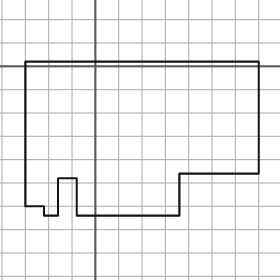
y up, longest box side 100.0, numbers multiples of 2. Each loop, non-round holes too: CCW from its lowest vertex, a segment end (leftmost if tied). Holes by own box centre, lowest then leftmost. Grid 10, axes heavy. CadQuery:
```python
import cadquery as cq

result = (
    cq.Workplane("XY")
    .moveTo(-22.0, -64.0)
    .lineTo(-16.0, -64.0)
    .lineTo(-16.0, -48.0)
    .lineTo(-8.0, -48.0)
    .lineTo(-8.0, -64.0)
    .lineTo(36.0, -64.0)
    .lineTo(36.0, -46.0)
    .lineTo(70.0, -46.0)
    .lineTo(70.0, 2.0)
    .lineTo(-30.0, 2.0)
    .lineTo(-30.0, -60.0)
    .lineTo(-22.0, -60.0)
    .close()
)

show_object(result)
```